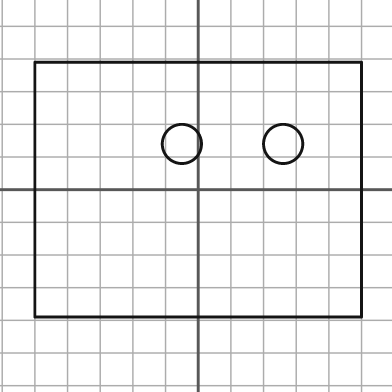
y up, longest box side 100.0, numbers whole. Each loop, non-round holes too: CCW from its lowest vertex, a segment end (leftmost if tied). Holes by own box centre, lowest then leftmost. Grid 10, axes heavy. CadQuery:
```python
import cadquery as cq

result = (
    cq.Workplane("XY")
    .moveTo(-50.0, -39.0)
    .lineTo(50.0, -39.0)
    .lineTo(50.0, 39.0)
    .lineTo(-50.0, 39.0)
    .close()
    .moveTo(-5.0, 14.0)
    .circle(6.0)
    .moveTo(26.0, 14.0)
    .circle(6.0)
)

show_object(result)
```